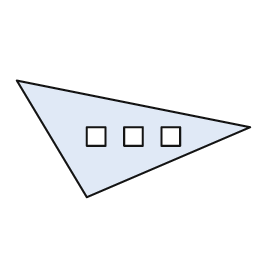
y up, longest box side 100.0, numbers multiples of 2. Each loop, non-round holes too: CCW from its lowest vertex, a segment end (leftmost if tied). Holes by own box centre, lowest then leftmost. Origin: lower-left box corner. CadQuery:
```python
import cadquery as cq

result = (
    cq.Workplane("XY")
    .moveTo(30.0, 0.0)
    .lineTo(100.0, 30.0)
    .lineTo(0.0, 50.0)
    .close()
    .moveTo(30.0, 22.0)
    .lineTo(38.0, 22.0)
    .lineTo(38.0, 30.0)
    .lineTo(30.0, 30.0)
    .close()
    .moveTo(46.0, 22.0)
    .lineTo(54.0, 22.0)
    .lineTo(54.0, 30.0)
    .lineTo(46.0, 30.0)
    .close()
    .moveTo(62.0, 22.0)
    .lineTo(70.0, 22.0)
    .lineTo(70.0, 30.0)
    .lineTo(62.0, 30.0)
    .close()
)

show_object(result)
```